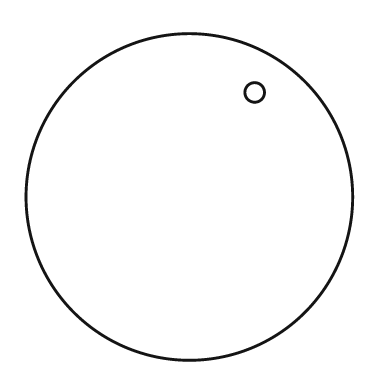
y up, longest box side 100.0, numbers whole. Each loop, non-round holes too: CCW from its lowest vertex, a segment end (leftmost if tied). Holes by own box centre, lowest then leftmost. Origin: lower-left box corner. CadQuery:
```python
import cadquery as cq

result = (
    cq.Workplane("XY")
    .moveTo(50.0, 50.0)
    .circle(50.0)
    .moveTo(70.0, 82.0)
    .circle(3.0)
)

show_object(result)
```